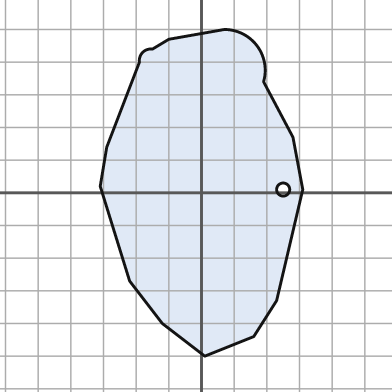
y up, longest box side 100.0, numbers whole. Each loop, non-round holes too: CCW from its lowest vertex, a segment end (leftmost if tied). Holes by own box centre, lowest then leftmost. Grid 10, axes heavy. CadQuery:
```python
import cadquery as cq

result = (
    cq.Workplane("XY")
    .moveTo(1.0, -50.0)
    .lineTo(16.0, -44.0)
    .lineTo(23.0, -33.0)
    .lineTo(31.0, 1.0)
    .lineTo(28.0, 17.0)
    .lineTo(19.0, 34.0)
    .threePointArc((17.0, 45.0), (7.0, 50.0))
    .lineTo(-10.0, 47.0)
    .lineTo(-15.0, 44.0)
    .threePointArc((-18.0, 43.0), (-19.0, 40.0))
    .lineTo(-29.0, 14.0)
    .lineTo(-31.0, 2.0)
    .lineTo(-22.0, -27.0)
    .lineTo(-12.0, -40.0)
    .close()
    .moveTo(25.0, 1.0)
    .circle(2.0)
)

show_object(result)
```